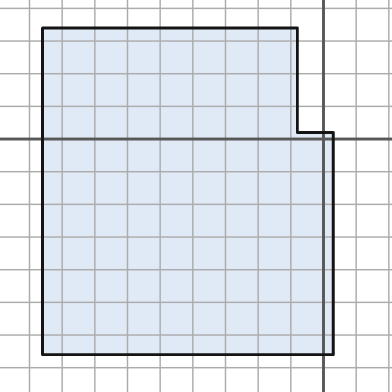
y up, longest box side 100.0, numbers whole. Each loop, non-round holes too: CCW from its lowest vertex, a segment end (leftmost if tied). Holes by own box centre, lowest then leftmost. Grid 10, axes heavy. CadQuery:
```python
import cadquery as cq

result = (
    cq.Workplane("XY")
    .moveTo(-86.0, -66.0)
    .lineTo(3.0, -66.0)
    .lineTo(3.0, 2.0)
    .lineTo(-8.0, 2.0)
    .lineTo(-8.0, 34.0)
    .lineTo(-86.0, 34.0)
    .close()
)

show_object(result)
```